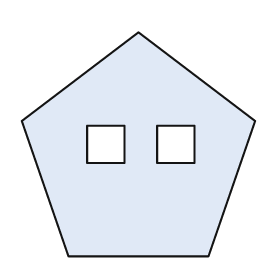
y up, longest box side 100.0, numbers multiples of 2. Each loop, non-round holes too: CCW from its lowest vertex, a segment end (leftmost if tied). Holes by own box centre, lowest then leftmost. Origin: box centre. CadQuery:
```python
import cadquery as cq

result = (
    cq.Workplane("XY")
    .moveTo(-30.0, -48.0)
    .lineTo(30.0, -48.0)
    .lineTo(50.0, 10.0)
    .lineTo(0.0, 48.0)
    .lineTo(-50.0, 10.0)
    .close()
    .moveTo(-22.0, -8.0)
    .lineTo(-6.0, -8.0)
    .lineTo(-6.0, 8.0)
    .lineTo(-22.0, 8.0)
    .close()
    .moveTo(8.0, -8.0)
    .lineTo(24.0, -8.0)
    .lineTo(24.0, 8.0)
    .lineTo(8.0, 8.0)
    .close()
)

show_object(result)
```